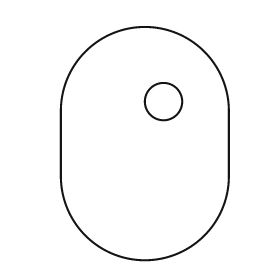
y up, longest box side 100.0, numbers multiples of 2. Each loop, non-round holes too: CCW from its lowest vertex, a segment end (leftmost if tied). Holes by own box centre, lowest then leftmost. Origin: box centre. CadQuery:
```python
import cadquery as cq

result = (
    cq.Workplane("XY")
    .moveTo(-36.0, -14.0)
    .threePointArc((0.0, -50.0), (36.0, -14.0))
    .lineTo(36.0, 14.0)
    .threePointArc((0.0, 50.0), (-36.0, 14.0))
    .close()
    .moveTo(8.0, 18.0)
    .circle(8.0)
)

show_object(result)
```